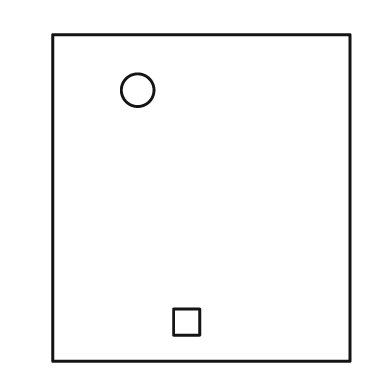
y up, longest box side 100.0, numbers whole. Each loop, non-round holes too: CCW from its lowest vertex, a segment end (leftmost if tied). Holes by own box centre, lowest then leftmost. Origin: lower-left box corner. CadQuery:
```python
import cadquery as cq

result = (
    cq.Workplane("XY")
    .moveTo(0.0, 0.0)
    .lineTo(91.0, 0.0)
    .lineTo(91.0, 100.0)
    .lineTo(0.0, 100.0)
    .close()
    .moveTo(37.0, 8.0)
    .lineTo(45.0, 8.0)
    .lineTo(45.0, 16.0)
    .lineTo(37.0, 16.0)
    .close()
    .moveTo(26.0, 83.0)
    .circle(5.0)
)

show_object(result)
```